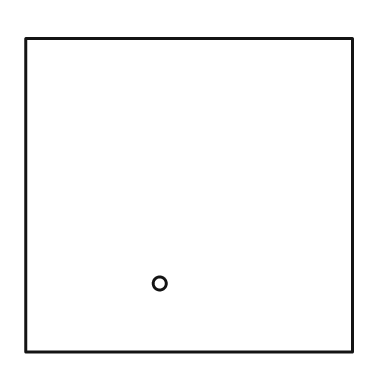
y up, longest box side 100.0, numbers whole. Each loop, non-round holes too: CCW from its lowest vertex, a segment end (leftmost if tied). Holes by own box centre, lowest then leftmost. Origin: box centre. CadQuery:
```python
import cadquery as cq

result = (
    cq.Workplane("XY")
    .moveTo(-50.0, -48.0)
    .lineTo(50.0, -48.0)
    .lineTo(50.0, 48.0)
    .lineTo(-50.0, 48.0)
    .close()
    .moveTo(-9.0, -27.0)
    .circle(2.0)
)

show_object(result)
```